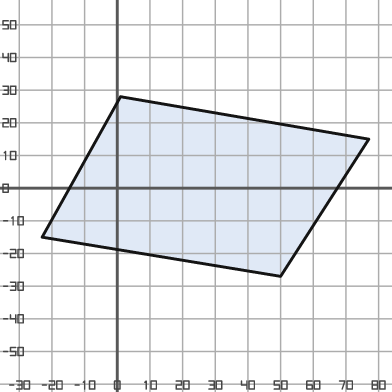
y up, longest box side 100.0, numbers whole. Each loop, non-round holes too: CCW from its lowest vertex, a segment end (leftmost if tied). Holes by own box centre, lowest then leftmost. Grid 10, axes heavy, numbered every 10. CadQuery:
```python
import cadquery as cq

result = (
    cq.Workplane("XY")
    .moveTo(50.0, -27.0)
    .lineTo(77.0, 15.0)
    .lineTo(1.0, 28.0)
    .lineTo(-23.0, -15.0)
    .close()
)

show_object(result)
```